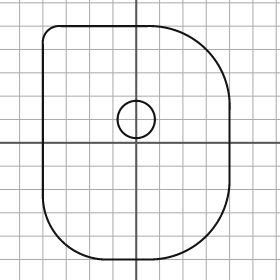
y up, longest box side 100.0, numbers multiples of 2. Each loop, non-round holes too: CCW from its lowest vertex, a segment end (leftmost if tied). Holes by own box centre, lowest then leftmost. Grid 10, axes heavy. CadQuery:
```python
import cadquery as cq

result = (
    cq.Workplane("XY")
    .moveTo(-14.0, -50.0)
    .lineTo(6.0, -50.0)
    .threePointArc((30.0, -40.0), (40.0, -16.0))
    .lineTo(40.0, 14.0)
    .threePointArc((30.0, 40.0), (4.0, 50.0))
    .lineTo(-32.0, 50.0)
    .threePointArc((-38.0, 48.0), (-40.0, 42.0))
    .lineTo(-40.0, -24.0)
    .threePointArc((-32.0, -42.0), (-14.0, -50.0))
    .close()
    .moveTo(0.0, 10.0)
    .circle(8.0)
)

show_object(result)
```